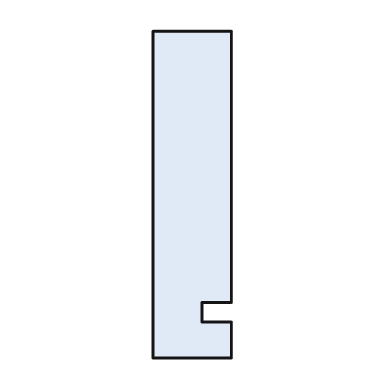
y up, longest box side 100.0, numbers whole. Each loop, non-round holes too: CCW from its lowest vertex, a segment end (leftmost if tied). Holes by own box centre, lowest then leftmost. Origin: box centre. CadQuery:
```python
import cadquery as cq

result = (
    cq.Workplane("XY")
    .moveTo(-12.0, -50.0)
    .lineTo(12.0, -50.0)
    .lineTo(12.0, -39.0)
    .lineTo(3.0, -39.0)
    .lineTo(3.0, -33.0)
    .lineTo(12.0, -33.0)
    .lineTo(12.0, 50.0)
    .lineTo(-12.0, 50.0)
    .close()
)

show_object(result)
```